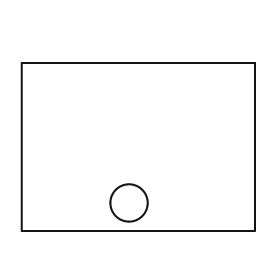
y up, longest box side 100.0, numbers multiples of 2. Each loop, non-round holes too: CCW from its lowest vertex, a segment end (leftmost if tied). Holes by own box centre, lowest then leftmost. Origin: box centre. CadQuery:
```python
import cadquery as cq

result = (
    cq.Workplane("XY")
    .moveTo(-50.0, -36.0)
    .lineTo(50.0, -36.0)
    .lineTo(50.0, 36.0)
    .lineTo(-50.0, 36.0)
    .close()
    .moveTo(-4.0, -24.0)
    .circle(8.0)
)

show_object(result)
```